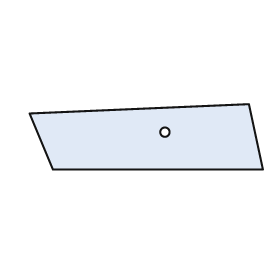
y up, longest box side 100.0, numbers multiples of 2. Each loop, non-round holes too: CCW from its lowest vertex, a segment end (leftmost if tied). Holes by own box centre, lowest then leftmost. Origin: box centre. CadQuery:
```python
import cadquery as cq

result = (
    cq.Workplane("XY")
    .moveTo(-40.0, -14.0)
    .lineTo(50.0, -14.0)
    .lineTo(44.0, 14.0)
    .lineTo(-50.0, 10.0)
    .close()
    .moveTo(8.0, 2.0)
    .circle(2.0)
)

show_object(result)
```